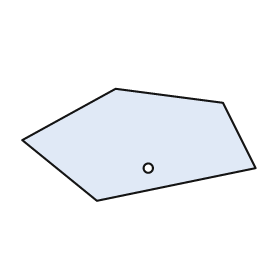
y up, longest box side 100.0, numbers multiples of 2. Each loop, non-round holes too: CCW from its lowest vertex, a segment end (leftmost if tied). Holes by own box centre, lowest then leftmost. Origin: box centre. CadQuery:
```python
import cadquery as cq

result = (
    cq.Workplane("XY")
    .moveTo(-18.0, -24.0)
    .lineTo(50.0, -10.0)
    .lineTo(36.0, 18.0)
    .lineTo(-10.0, 24.0)
    .lineTo(-50.0, 2.0)
    .close()
    .moveTo(4.0, -10.0)
    .circle(2.0)
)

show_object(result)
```